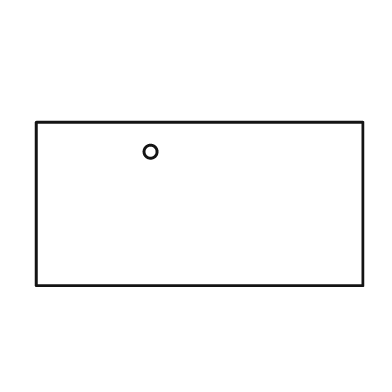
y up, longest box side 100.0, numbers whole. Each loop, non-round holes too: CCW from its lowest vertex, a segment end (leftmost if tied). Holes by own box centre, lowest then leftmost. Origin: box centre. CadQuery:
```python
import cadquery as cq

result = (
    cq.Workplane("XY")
    .moveTo(-50.0, -25.0)
    .lineTo(50.0, -25.0)
    .lineTo(50.0, 25.0)
    .lineTo(-50.0, 25.0)
    .close()
    .moveTo(-15.0, 16.0)
    .circle(2.0)
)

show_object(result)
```